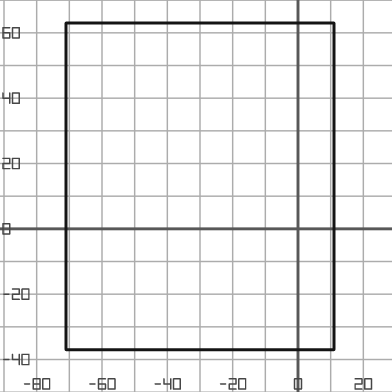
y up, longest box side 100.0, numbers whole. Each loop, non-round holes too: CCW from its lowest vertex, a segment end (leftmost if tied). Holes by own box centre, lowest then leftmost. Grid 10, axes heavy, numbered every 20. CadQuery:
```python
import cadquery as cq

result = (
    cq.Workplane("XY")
    .moveTo(-71.0, -37.0)
    .lineTo(11.0, -37.0)
    .lineTo(11.0, 63.0)
    .lineTo(-71.0, 63.0)
    .close()
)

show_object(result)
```